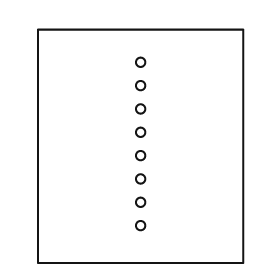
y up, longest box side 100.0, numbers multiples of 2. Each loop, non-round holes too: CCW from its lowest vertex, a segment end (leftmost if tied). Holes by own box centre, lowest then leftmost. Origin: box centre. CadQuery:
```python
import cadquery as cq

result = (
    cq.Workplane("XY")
    .moveTo(-44.0, -50.0)
    .lineTo(44.0, -50.0)
    .lineTo(44.0, 50.0)
    .lineTo(-44.0, 50.0)
    .close()
    .moveTo(0.0, -34.0)
    .circle(2.0)
    .moveTo(0.0, -24.0)
    .circle(2.0)
    .moveTo(0.0, -14.0)
    .circle(2.0)
    .moveTo(0.0, -4.0)
    .circle(2.0)
    .moveTo(0.0, 6.0)
    .circle(2.0)
    .moveTo(0.0, 16.0)
    .circle(2.0)
    .moveTo(0.0, 26.0)
    .circle(2.0)
    .moveTo(0.0, 36.0)
    .circle(2.0)
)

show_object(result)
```